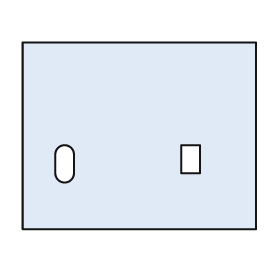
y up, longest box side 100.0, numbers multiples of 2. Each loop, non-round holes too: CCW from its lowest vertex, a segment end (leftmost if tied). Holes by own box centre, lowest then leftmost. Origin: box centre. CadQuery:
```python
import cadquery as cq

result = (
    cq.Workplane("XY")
    .moveTo(-50.0, -40.0)
    .lineTo(50.0, -40.0)
    .lineTo(50.0, 40.0)
    .lineTo(-50.0, 40.0)
    .close()
    .moveTo(-36.0, -16.0)
    .threePointArc((-32.0, -20.0), (-28.0, -16.0))
    .lineTo(-28.0, -8.0)
    .threePointArc((-32.0, -4.0), (-36.0, -8.0))
    .close()
    .moveTo(18.0, -16.0)
    .lineTo(26.0, -16.0)
    .lineTo(26.0, -4.0)
    .lineTo(18.0, -4.0)
    .close()
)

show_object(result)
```